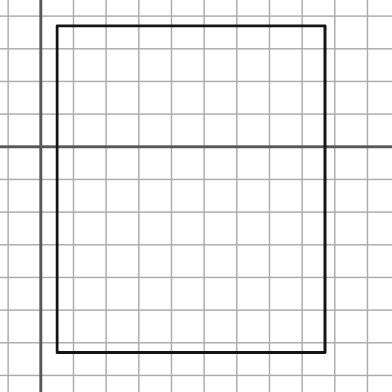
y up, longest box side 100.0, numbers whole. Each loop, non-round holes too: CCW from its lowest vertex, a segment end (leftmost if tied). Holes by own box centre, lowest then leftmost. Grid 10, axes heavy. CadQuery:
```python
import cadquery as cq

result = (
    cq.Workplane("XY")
    .moveTo(5.0, -63.0)
    .lineTo(87.0, -63.0)
    .lineTo(87.0, 37.0)
    .lineTo(5.0, 37.0)
    .close()
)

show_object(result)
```